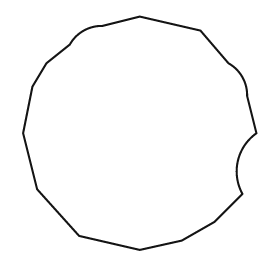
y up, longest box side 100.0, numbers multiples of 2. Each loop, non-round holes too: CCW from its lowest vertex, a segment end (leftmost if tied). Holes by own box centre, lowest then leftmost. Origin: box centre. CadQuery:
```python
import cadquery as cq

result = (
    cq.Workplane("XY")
    .moveTo(0.0, -50.0)
    .lineTo(18.0, -46.0)
    .lineTo(32.0, -38.0)
    .lineTo(44.0, -26.0)
    .threePointArc((42.0, -12.0), (50.0, 0.0))
    .lineTo(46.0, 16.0)
    .threePointArc((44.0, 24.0), (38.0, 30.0))
    .lineTo(26.0, 44.0)
    .lineTo(0.0, 50.0)
    .lineTo(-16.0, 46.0)
    .threePointArc((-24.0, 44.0), (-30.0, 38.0))
    .lineTo(-40.0, 30.0)
    .lineTo(-46.0, 20.0)
    .lineTo(-50.0, 0.0)
    .lineTo(-44.0, -24.0)
    .lineTo(-26.0, -44.0)
    .close()
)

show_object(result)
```